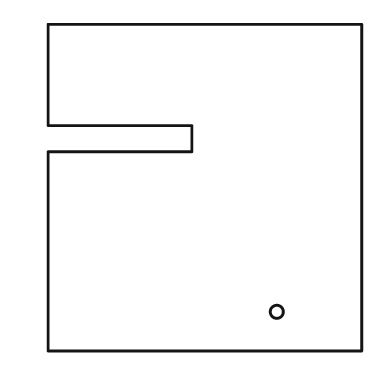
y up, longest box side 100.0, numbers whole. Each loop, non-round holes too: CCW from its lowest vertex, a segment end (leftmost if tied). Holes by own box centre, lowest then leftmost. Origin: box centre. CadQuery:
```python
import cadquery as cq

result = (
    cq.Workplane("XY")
    .moveTo(-48.0, -50.0)
    .lineTo(48.0, -50.0)
    .lineTo(48.0, 50.0)
    .lineTo(-48.0, 50.0)
    .lineTo(-48.0, 19.0)
    .lineTo(-4.0, 19.0)
    .lineTo(-4.0, 11.0)
    .lineTo(-48.0, 11.0)
    .close()
    .moveTo(22.0, -38.0)
    .circle(2.0)
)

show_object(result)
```